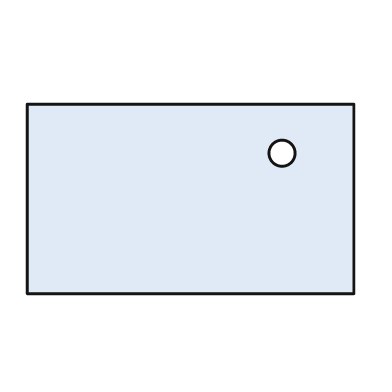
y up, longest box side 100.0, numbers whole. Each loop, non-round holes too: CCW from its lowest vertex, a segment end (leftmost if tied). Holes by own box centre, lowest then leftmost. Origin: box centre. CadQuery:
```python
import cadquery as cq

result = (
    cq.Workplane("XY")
    .moveTo(-50.0, -29.0)
    .lineTo(50.0, -29.0)
    .lineTo(50.0, 29.0)
    .lineTo(-50.0, 29.0)
    .close()
    .moveTo(28.0, 14.0)
    .circle(4.0)
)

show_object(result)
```